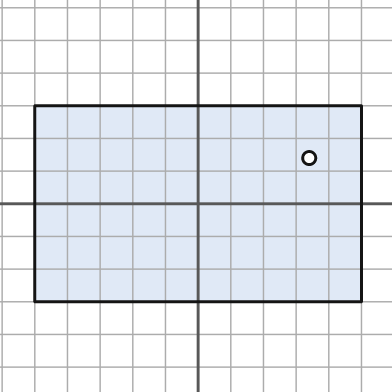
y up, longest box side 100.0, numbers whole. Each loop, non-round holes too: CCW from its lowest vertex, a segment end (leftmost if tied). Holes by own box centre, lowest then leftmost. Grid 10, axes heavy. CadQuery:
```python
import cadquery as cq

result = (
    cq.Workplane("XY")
    .moveTo(-50.0, -30.0)
    .lineTo(50.0, -30.0)
    .lineTo(50.0, 30.0)
    .lineTo(-50.0, 30.0)
    .close()
    .moveTo(34.0, 14.0)
    .circle(2.0)
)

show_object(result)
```